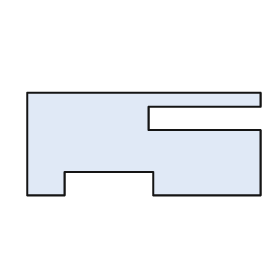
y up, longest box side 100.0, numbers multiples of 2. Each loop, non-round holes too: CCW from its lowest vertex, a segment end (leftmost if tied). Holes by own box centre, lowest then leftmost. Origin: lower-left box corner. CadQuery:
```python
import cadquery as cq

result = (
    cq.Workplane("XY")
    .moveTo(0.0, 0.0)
    .lineTo(16.0, 0.0)
    .lineTo(16.0, 10.0)
    .lineTo(54.0, 10.0)
    .lineTo(54.0, 0.0)
    .lineTo(100.0, 0.0)
    .lineTo(100.0, 28.0)
    .lineTo(52.0, 28.0)
    .lineTo(52.0, 38.0)
    .lineTo(100.0, 38.0)
    .lineTo(100.0, 44.0)
    .lineTo(0.0, 44.0)
    .close()
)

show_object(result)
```